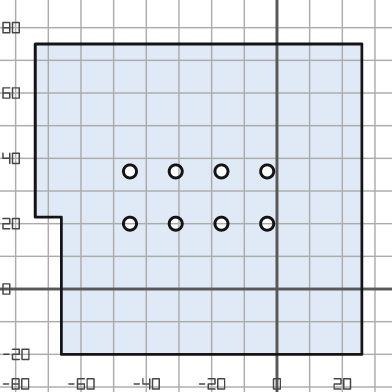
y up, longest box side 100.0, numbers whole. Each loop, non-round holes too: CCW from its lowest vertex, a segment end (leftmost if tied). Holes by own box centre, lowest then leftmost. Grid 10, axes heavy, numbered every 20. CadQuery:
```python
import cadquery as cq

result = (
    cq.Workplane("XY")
    .moveTo(-66.0, -20.0)
    .lineTo(26.0, -20.0)
    .lineTo(26.0, 75.0)
    .lineTo(-74.0, 75.0)
    .lineTo(-74.0, 22.0)
    .lineTo(-66.0, 22.0)
    .close()
    .moveTo(-45.0, 20.0)
    .circle(2.0)
    .moveTo(-31.0, 20.0)
    .circle(2.0)
    .moveTo(-17.0, 20.0)
    .circle(2.0)
    .moveTo(-3.0, 20.0)
    .circle(2.0)
    .moveTo(-45.0, 36.0)
    .circle(2.0)
    .moveTo(-31.0, 36.0)
    .circle(2.0)
    .moveTo(-17.0, 36.0)
    .circle(2.0)
    .moveTo(-3.0, 36.0)
    .circle(2.0)
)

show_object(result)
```